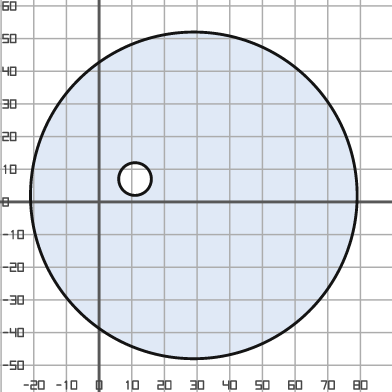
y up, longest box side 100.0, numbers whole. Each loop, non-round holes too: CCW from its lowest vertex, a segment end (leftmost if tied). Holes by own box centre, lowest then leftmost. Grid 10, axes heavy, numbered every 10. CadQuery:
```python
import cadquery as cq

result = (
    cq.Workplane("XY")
    .moveTo(29.0, 2.0)
    .circle(50.0)
    .moveTo(11.0, 7.0)
    .circle(5.0)
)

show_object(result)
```